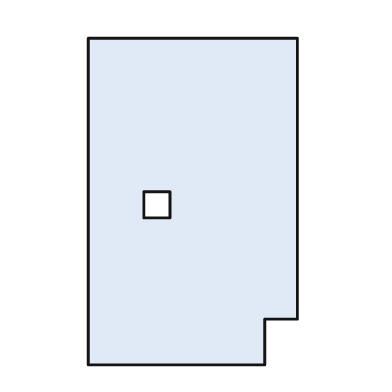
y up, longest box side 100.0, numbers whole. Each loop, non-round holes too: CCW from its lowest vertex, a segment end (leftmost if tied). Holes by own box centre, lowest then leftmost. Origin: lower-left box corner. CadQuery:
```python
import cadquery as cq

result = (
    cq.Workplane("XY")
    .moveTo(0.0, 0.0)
    .lineTo(54.0, 0.0)
    .lineTo(54.0, 14.0)
    .lineTo(64.0, 14.0)
    .lineTo(64.0, 100.0)
    .lineTo(0.0, 100.0)
    .close()
    .moveTo(17.0, 45.0)
    .lineTo(25.0, 45.0)
    .lineTo(25.0, 53.0)
    .lineTo(17.0, 53.0)
    .close()
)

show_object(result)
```